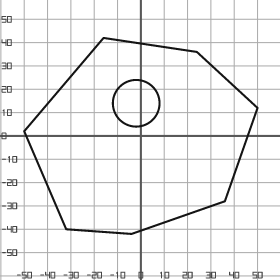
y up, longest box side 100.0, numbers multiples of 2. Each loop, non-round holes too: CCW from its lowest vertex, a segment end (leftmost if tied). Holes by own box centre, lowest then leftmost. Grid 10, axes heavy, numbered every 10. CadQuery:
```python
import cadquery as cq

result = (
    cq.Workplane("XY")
    .moveTo(-4.0, -42.0)
    .lineTo(36.0, -28.0)
    .lineTo(50.0, 12.0)
    .lineTo(24.0, 36.0)
    .lineTo(-16.0, 42.0)
    .lineTo(-50.0, 2.0)
    .lineTo(-32.0, -40.0)
    .close()
    .moveTo(-2.0, 14.0)
    .circle(10.0)
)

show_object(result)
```